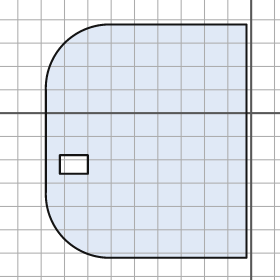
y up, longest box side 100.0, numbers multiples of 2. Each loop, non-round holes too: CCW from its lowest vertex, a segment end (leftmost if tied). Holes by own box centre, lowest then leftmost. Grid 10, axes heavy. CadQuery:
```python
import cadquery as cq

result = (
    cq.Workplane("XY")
    .moveTo(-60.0, -62.0)
    .lineTo(-2.0, -62.0)
    .lineTo(-2.0, 38.0)
    .lineTo(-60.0, 38.0)
    .threePointArc((-80.0, 30.0), (-88.0, 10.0))
    .lineTo(-88.0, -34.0)
    .threePointArc((-80.0, -54.0), (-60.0, -62.0))
    .close()
    .moveTo(-82.0, -26.0)
    .lineTo(-70.0, -26.0)
    .lineTo(-70.0, -18.0)
    .lineTo(-82.0, -18.0)
    .close()
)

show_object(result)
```